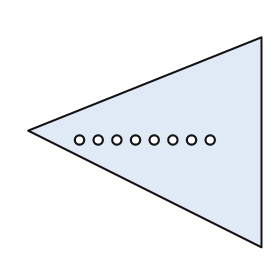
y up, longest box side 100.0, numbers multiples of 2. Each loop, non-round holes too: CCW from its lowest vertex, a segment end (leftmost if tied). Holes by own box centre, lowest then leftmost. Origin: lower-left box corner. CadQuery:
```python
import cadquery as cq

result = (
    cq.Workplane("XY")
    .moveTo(100.0, 0.0)
    .lineTo(100.0, 90.0)
    .lineTo(0.0, 50.0)
    .close()
    .moveTo(22.0, 46.0)
    .circle(2.0)
    .moveTo(30.0, 46.0)
    .circle(2.0)
    .moveTo(38.0, 46.0)
    .circle(2.0)
    .moveTo(46.0, 46.0)
    .circle(2.0)
    .moveTo(54.0, 46.0)
    .circle(2.0)
    .moveTo(62.0, 46.0)
    .circle(2.0)
    .moveTo(70.0, 46.0)
    .circle(2.0)
    .moveTo(78.0, 46.0)
    .circle(2.0)
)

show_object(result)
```